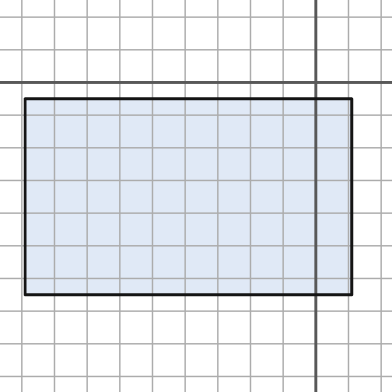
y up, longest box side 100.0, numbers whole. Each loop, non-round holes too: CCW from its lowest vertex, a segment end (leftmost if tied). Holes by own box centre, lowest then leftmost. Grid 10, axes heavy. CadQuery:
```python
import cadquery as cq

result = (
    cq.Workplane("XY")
    .moveTo(-89.0, -65.0)
    .lineTo(11.0, -65.0)
    .lineTo(11.0, -5.0)
    .lineTo(-89.0, -5.0)
    .close()
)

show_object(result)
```